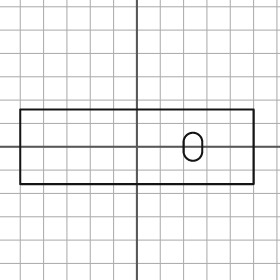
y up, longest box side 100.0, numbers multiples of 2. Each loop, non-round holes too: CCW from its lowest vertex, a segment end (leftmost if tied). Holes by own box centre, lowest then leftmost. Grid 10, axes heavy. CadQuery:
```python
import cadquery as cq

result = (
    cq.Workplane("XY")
    .moveTo(-50.0, -16.0)
    .lineTo(50.0, -16.0)
    .lineTo(50.0, 16.0)
    .lineTo(-50.0, 16.0)
    .close()
    .moveTo(20.0, -2.0)
    .threePointArc((24.0, -6.0), (28.0, -2.0))
    .lineTo(28.0, 2.0)
    .threePointArc((24.0, 6.0), (20.0, 2.0))
    .close()
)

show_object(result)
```